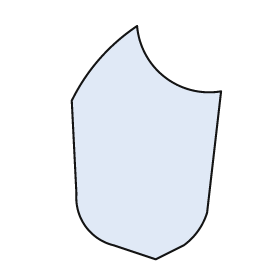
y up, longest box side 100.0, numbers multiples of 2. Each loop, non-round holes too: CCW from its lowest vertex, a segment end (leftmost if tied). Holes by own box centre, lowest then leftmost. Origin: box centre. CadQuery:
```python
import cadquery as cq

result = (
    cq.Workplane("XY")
    .moveTo(4.0, -50.0)
    .lineTo(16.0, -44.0)
    .threePointArc((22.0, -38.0), (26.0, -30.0))
    .lineTo(32.0, 22.0)
    .threePointArc((8.0, 28.0), (-4.0, 50.0))
    .threePointArc((-20.0, 36.0), (-32.0, 18.0))
    .lineTo(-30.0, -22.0)
    .threePointArc((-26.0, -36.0), (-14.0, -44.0))
    .close()
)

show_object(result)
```